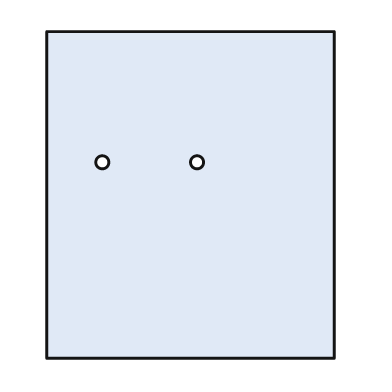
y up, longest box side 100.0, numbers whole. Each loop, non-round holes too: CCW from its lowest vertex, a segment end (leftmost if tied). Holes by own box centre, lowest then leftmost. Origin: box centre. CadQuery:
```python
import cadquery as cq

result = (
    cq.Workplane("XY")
    .moveTo(-44.0, -50.0)
    .lineTo(44.0, -50.0)
    .lineTo(44.0, 50.0)
    .lineTo(-44.0, 50.0)
    .close()
    .moveTo(-27.0, 10.0)
    .circle(2.0)
    .moveTo(2.0, 10.0)
    .circle(2.0)
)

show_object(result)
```